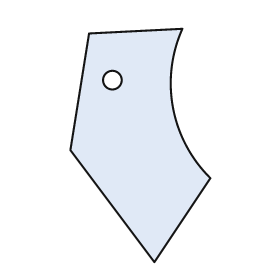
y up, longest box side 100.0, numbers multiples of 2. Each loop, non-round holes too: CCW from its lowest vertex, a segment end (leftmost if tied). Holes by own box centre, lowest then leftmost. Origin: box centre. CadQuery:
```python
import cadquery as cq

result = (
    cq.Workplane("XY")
    .moveTo(6.0, -50.0)
    .lineTo(30.0, -14.0)
    .threePointArc((14.0, 16.0), (18.0, 50.0))
    .lineTo(-22.0, 48.0)
    .lineTo(-30.0, -2.0)
    .close()
    .moveTo(-12.0, 28.0)
    .circle(4.0)
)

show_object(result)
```